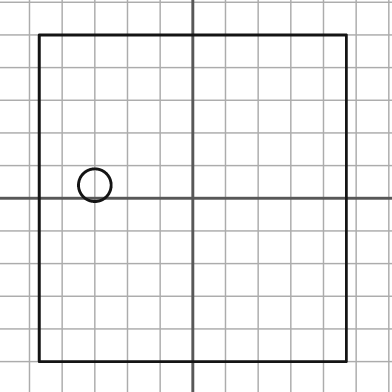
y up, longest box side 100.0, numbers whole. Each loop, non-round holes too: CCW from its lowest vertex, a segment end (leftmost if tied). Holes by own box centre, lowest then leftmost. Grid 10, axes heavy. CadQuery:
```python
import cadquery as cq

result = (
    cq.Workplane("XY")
    .moveTo(-47.0, -50.0)
    .lineTo(47.0, -50.0)
    .lineTo(47.0, 50.0)
    .lineTo(-47.0, 50.0)
    .close()
    .moveTo(-30.0, 4.0)
    .circle(5.0)
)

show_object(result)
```